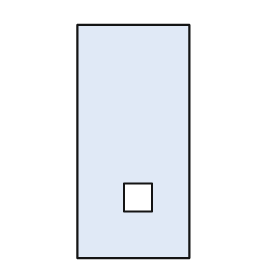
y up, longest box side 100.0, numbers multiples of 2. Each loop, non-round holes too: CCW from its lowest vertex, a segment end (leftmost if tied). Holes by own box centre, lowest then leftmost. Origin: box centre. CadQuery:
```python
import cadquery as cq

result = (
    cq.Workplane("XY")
    .moveTo(-24.0, -50.0)
    .lineTo(24.0, -50.0)
    .lineTo(24.0, 50.0)
    .lineTo(-24.0, 50.0)
    .close()
    .moveTo(-4.0, -30.0)
    .lineTo(8.0, -30.0)
    .lineTo(8.0, -18.0)
    .lineTo(-4.0, -18.0)
    .close()
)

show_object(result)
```